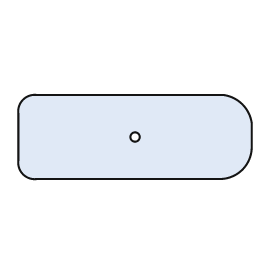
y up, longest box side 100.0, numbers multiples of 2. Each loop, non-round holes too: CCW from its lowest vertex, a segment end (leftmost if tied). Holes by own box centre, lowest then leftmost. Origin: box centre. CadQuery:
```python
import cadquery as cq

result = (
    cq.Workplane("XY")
    .moveTo(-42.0, -18.0)
    .lineTo(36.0, -18.0)
    .threePointArc((46.0, -14.0), (50.0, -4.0))
    .lineTo(50.0, 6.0)
    .threePointArc((46.0, 14.0), (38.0, 18.0))
    .lineTo(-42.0, 18.0)
    .threePointArc((-48.0, 16.0), (-50.0, 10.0))
    .lineTo(-50.0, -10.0)
    .threePointArc((-48.0, -16.0), (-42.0, -18.0))
    .close()
    .moveTo(0.0, 0.0)
    .circle(2.0)
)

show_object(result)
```